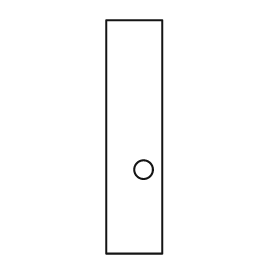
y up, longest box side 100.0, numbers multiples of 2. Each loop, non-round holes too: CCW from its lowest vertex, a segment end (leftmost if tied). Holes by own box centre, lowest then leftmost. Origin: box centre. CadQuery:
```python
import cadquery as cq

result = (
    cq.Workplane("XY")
    .moveTo(-12.0, -50.0)
    .lineTo(12.0, -50.0)
    .lineTo(12.0, 50.0)
    .lineTo(-12.0, 50.0)
    .close()
    .moveTo(4.0, -14.0)
    .circle(4.0)
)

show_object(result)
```